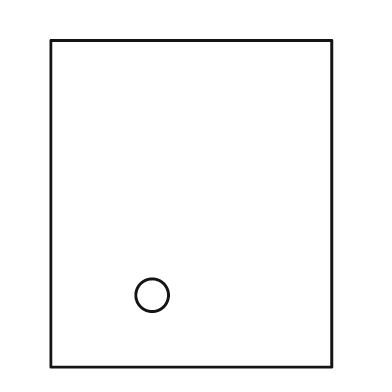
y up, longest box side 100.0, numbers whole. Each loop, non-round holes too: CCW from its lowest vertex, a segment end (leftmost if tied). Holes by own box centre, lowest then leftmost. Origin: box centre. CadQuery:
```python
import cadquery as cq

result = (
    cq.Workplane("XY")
    .moveTo(-43.0, -50.0)
    .lineTo(43.0, -50.0)
    .lineTo(43.0, 50.0)
    .lineTo(-43.0, 50.0)
    .close()
    .moveTo(-12.0, -28.0)
    .circle(5.0)
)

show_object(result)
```